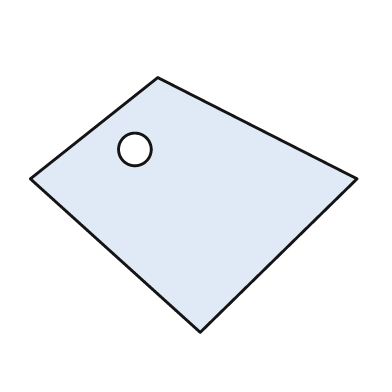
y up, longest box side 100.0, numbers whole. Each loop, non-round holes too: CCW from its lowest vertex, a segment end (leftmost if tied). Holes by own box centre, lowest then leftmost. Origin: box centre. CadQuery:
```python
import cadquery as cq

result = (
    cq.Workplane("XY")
    .moveTo(2.0, -39.0)
    .lineTo(50.0, 8.0)
    .lineTo(-11.0, 39.0)
    .lineTo(-50.0, 8.0)
    .close()
    .moveTo(-18.0, 17.0)
    .circle(5.0)
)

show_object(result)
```